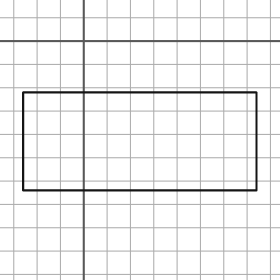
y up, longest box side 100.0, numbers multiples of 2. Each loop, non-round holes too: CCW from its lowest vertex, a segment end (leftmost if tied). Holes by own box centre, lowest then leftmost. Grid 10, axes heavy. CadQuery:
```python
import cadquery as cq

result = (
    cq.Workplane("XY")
    .moveTo(-26.0, -64.0)
    .lineTo(74.0, -64.0)
    .lineTo(74.0, -22.0)
    .lineTo(-26.0, -22.0)
    .close()
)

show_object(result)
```